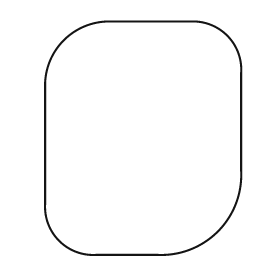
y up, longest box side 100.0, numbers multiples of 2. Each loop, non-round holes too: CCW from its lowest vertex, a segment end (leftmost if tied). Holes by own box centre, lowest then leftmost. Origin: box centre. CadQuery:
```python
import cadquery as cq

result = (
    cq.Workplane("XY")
    .moveTo(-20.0, -50.0)
    .lineTo(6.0, -50.0)
    .threePointArc((32.0, -40.0), (42.0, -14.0))
    .lineTo(42.0, 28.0)
    .threePointArc((36.0, 44.0), (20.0, 50.0))
    .lineTo(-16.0, 50.0)
    .threePointArc((-34.0, 42.0), (-42.0, 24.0))
    .lineTo(-42.0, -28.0)
    .threePointArc((-36.0, -44.0), (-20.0, -50.0))
    .close()
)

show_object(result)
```